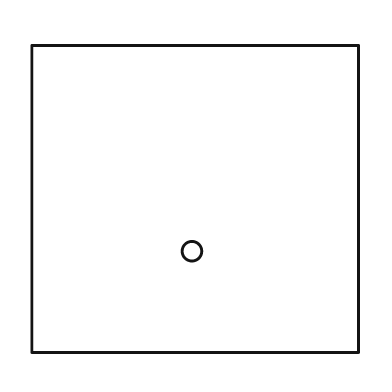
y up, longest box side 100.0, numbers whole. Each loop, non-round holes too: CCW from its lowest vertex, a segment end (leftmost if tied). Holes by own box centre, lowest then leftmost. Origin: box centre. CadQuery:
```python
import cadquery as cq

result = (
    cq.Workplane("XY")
    .moveTo(-50.0, -47.0)
    .lineTo(50.0, -47.0)
    .lineTo(50.0, 47.0)
    .lineTo(-50.0, 47.0)
    .close()
    .moveTo(-1.0, -16.0)
    .circle(3.0)
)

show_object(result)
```